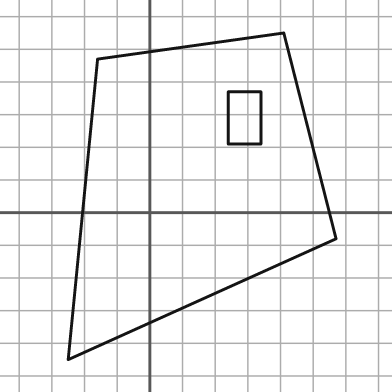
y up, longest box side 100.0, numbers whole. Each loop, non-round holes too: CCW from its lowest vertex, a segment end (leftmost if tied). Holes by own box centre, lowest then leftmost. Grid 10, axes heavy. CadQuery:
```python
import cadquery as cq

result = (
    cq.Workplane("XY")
    .moveTo(-25.0, -45.0)
    .lineTo(57.0, -8.0)
    .lineTo(41.0, 55.0)
    .lineTo(-16.0, 47.0)
    .close()
    .moveTo(24.0, 21.0)
    .lineTo(34.0, 21.0)
    .lineTo(34.0, 37.0)
    .lineTo(24.0, 37.0)
    .close()
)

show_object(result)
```